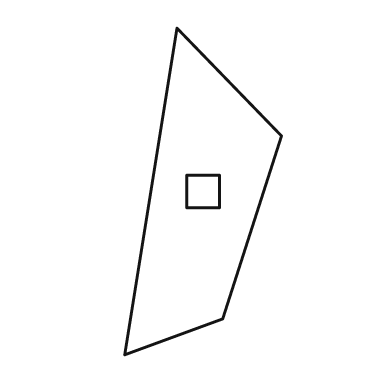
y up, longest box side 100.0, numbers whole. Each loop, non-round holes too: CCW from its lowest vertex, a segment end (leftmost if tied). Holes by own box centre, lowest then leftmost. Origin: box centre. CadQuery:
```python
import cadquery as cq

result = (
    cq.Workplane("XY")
    .moveTo(-24.0, -50.0)
    .lineTo(6.0, -39.0)
    .lineTo(24.0, 17.0)
    .lineTo(-8.0, 50.0)
    .close()
    .moveTo(-5.0, -5.0)
    .lineTo(5.0, -5.0)
    .lineTo(5.0, 5.0)
    .lineTo(-5.0, 5.0)
    .close()
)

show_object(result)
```